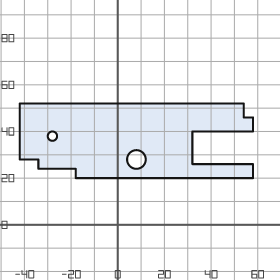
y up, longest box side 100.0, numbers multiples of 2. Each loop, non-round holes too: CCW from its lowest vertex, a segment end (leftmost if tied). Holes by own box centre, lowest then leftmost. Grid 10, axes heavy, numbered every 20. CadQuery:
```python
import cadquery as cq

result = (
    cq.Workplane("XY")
    .moveTo(-18.0, 20.0)
    .lineTo(58.0, 20.0)
    .lineTo(58.0, 26.0)
    .lineTo(32.0, 26.0)
    .lineTo(32.0, 40.0)
    .lineTo(58.0, 40.0)
    .lineTo(58.0, 46.0)
    .lineTo(54.0, 46.0)
    .lineTo(54.0, 52.0)
    .lineTo(-42.0, 52.0)
    .lineTo(-42.0, 28.0)
    .lineTo(-34.0, 28.0)
    .lineTo(-34.0, 24.0)
    .lineTo(-18.0, 24.0)
    .close()
    .moveTo(8.0, 28.0)
    .circle(4.0)
    .moveTo(-28.0, 38.0)
    .circle(2.0)
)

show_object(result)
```